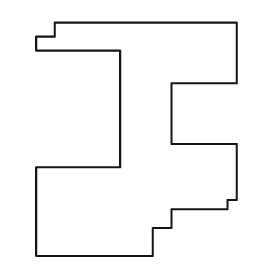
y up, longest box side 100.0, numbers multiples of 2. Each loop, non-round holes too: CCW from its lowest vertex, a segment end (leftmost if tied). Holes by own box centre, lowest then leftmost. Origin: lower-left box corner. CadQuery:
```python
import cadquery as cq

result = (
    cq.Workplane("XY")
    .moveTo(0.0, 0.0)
    .lineTo(50.0, 0.0)
    .lineTo(50.0, 12.0)
    .lineTo(58.0, 12.0)
    .lineTo(58.0, 20.0)
    .lineTo(82.0, 20.0)
    .lineTo(82.0, 24.0)
    .lineTo(86.0, 24.0)
    .lineTo(86.0, 48.0)
    .lineTo(58.0, 48.0)
    .lineTo(58.0, 74.0)
    .lineTo(86.0, 74.0)
    .lineTo(86.0, 100.0)
    .lineTo(8.0, 100.0)
    .lineTo(8.0, 94.0)
    .lineTo(0.0, 94.0)
    .lineTo(0.0, 88.0)
    .lineTo(36.0, 88.0)
    .lineTo(36.0, 38.0)
    .lineTo(0.0, 38.0)
    .close()
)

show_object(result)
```